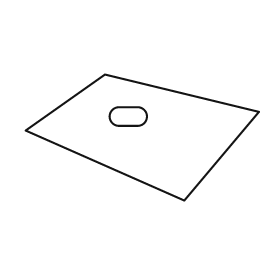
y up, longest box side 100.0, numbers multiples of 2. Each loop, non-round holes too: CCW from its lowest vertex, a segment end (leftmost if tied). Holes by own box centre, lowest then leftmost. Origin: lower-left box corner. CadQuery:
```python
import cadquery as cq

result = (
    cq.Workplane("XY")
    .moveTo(68.0, 0.0)
    .lineTo(100.0, 38.0)
    .lineTo(34.0, 54.0)
    .lineTo(0.0, 30.0)
    .close()
    .moveTo(40.0, 32.0)
    .lineTo(48.0, 32.0)
    .threePointArc((52.0, 36.0), (48.0, 40.0))
    .lineTo(40.0, 40.0)
    .threePointArc((36.0, 36.0), (40.0, 32.0))
    .close()
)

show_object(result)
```